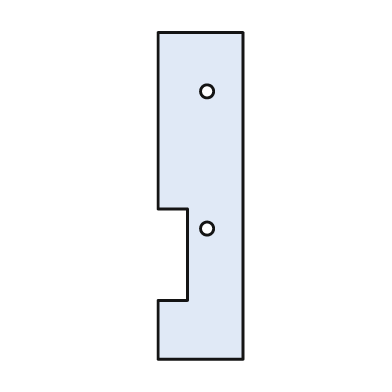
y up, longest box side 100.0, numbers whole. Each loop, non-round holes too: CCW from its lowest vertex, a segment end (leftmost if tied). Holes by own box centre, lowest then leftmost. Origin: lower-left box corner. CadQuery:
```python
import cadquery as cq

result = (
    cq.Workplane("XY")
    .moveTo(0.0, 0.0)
    .lineTo(26.0, 0.0)
    .lineTo(26.0, 100.0)
    .lineTo(0.0, 100.0)
    .lineTo(0.0, 46.0)
    .lineTo(9.0, 46.0)
    .lineTo(9.0, 18.0)
    .lineTo(0.0, 18.0)
    .close()
    .moveTo(15.0, 40.0)
    .circle(2.0)
    .moveTo(15.0, 82.0)
    .circle(2.0)
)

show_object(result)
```